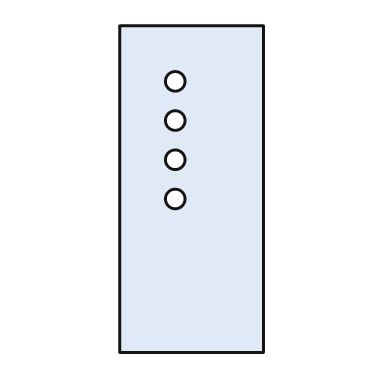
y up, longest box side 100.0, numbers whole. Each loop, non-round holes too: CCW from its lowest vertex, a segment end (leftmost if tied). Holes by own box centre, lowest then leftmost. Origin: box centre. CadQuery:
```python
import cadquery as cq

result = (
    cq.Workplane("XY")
    .moveTo(-22.0, -50.0)
    .lineTo(22.0, -50.0)
    .lineTo(22.0, 50.0)
    .lineTo(-22.0, 50.0)
    .close()
    .moveTo(-5.0, -3.0)
    .circle(3.0)
    .moveTo(-5.0, 9.0)
    .circle(3.0)
    .moveTo(-5.0, 21.0)
    .circle(3.0)
    .moveTo(-5.0, 33.0)
    .circle(3.0)
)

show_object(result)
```